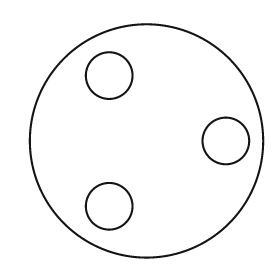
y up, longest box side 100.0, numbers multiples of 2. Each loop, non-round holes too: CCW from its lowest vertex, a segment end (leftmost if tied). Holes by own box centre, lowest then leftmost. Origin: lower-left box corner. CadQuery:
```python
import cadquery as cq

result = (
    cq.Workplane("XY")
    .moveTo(50.0, 50.0)
    .circle(50.0)
    .moveTo(34.0, 22.0)
    .circle(10.0)
    .moveTo(84.0, 50.0)
    .circle(10.0)
    .moveTo(34.0, 78.0)
    .circle(10.0)
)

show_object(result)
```